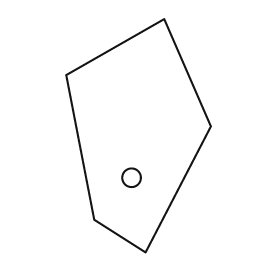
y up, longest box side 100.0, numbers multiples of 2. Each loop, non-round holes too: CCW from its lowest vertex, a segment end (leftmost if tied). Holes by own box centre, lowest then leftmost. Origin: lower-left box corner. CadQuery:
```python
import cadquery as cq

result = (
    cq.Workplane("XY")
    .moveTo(34.0, 0.0)
    .lineTo(62.0, 54.0)
    .lineTo(42.0, 100.0)
    .lineTo(0.0, 76.0)
    .lineTo(12.0, 14.0)
    .close()
    .moveTo(28.0, 32.0)
    .circle(4.0)
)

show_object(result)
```